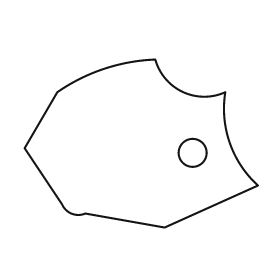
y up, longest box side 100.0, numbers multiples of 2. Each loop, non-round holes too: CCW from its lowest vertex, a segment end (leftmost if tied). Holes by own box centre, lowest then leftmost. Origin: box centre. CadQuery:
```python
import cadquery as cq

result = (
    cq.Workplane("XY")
    .moveTo(10.0, -36.0)
    .lineTo(50.0, -18.0)
    .threePointArc((38.0, 0.0), (36.0, 22.0))
    .threePointArc((18.0, 22.0), (6.0, 36.0))
    .threePointArc((-16.0, 32.0), (-36.0, 22.0))
    .lineTo(-50.0, -2.0)
    .lineTo(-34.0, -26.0)
    .threePointArc((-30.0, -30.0), (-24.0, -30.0))
    .close()
    .moveTo(22.0, -4.0)
    .circle(6.0)
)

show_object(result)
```